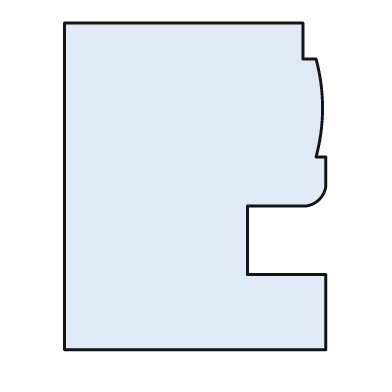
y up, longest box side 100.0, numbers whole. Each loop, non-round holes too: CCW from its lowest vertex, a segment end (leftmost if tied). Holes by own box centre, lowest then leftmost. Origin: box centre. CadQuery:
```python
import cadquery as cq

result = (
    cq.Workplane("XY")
    .moveTo(-40.0, -50.0)
    .lineTo(40.0, -50.0)
    .lineTo(40.0, -27.0)
    .lineTo(16.0, -27.0)
    .lineTo(16.0, -6.0)
    .lineTo(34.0, -6.0)
    .threePointArc((38.0, -4.0), (40.0, 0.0))
    .lineTo(40.0, 9.0)
    .lineTo(37.0, 9.0)
    .threePointArc((39.0, 24.0), (37.0, 39.0))
    .lineTo(33.0, 39.0)
    .lineTo(33.0, 50.0)
    .lineTo(-40.0, 50.0)
    .close()
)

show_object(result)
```